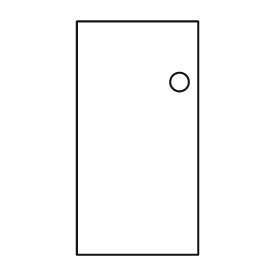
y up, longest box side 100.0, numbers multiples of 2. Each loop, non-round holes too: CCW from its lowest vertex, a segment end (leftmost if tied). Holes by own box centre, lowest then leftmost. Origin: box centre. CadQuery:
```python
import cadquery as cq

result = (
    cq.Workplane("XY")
    .moveTo(-26.0, -50.0)
    .lineTo(26.0, -50.0)
    .lineTo(26.0, 50.0)
    .lineTo(-26.0, 50.0)
    .close()
    .moveTo(18.0, 24.0)
    .circle(4.0)
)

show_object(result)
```